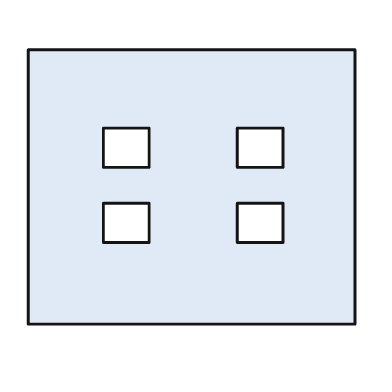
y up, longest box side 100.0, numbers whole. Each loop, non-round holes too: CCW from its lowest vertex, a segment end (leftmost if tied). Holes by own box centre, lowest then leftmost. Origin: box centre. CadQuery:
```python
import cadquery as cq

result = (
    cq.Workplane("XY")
    .moveTo(-50.0, -42.0)
    .lineTo(50.0, -42.0)
    .lineTo(50.0, 42.0)
    .lineTo(-50.0, 42.0)
    .close()
    .moveTo(-27.0, -17.0)
    .lineTo(-13.0, -17.0)
    .lineTo(-13.0, -5.0)
    .lineTo(-27.0, -5.0)
    .close()
    .moveTo(14.0, -17.0)
    .lineTo(28.0, -17.0)
    .lineTo(28.0, -5.0)
    .lineTo(14.0, -5.0)
    .close()
    .moveTo(-27.0, 6.0)
    .lineTo(-13.0, 6.0)
    .lineTo(-13.0, 18.0)
    .lineTo(-27.0, 18.0)
    .close()
    .moveTo(14.0, 6.0)
    .lineTo(28.0, 6.0)
    .lineTo(28.0, 18.0)
    .lineTo(14.0, 18.0)
    .close()
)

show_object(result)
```